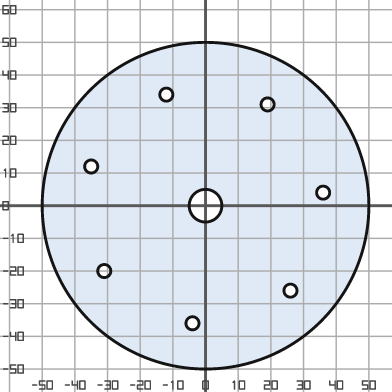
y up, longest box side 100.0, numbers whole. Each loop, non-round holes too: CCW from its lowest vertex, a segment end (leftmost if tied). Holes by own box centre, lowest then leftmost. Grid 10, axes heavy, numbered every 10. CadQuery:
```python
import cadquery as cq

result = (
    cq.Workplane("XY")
    .moveTo(0.0, 0.0)
    .circle(50.0)
    .moveTo(-4.0, -36.0)
    .circle(2.0)
    .moveTo(26.0, -26.0)
    .circle(2.0)
    .moveTo(-31.0, -20.0)
    .circle(2.0)
    .moveTo(0.0, 0.0)
    .circle(5.0)
    .moveTo(36.0, 4.0)
    .circle(2.0)
    .moveTo(-35.0, 12.0)
    .circle(2.0)
    .moveTo(19.0, 31.0)
    .circle(2.0)
    .moveTo(-12.0, 34.0)
    .circle(2.0)
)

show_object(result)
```